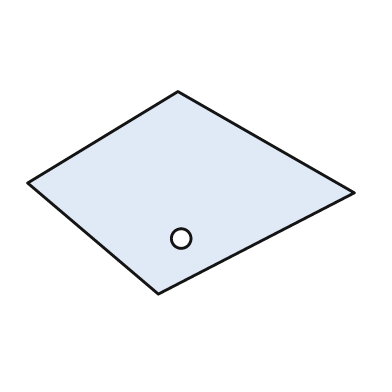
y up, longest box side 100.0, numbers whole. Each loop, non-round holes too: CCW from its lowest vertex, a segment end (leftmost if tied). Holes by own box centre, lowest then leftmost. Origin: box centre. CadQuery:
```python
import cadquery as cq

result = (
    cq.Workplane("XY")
    .moveTo(-10.0, -31.0)
    .lineTo(50.0, 0.0)
    .lineTo(-4.0, 31.0)
    .lineTo(-50.0, 3.0)
    .close()
    .moveTo(-3.0, -14.0)
    .circle(3.0)
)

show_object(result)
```